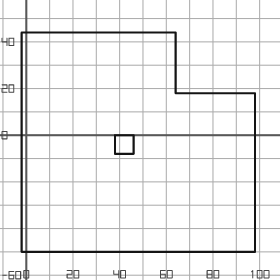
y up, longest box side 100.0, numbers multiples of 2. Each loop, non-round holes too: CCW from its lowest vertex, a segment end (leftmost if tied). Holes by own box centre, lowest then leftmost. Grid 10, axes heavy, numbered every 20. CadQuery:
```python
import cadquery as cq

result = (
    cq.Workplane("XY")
    .moveTo(-2.0, -50.0)
    .lineTo(98.0, -50.0)
    .lineTo(98.0, 18.0)
    .lineTo(64.0, 18.0)
    .lineTo(64.0, 44.0)
    .lineTo(-2.0, 44.0)
    .close()
    .moveTo(38.0, -8.0)
    .lineTo(46.0, -8.0)
    .lineTo(46.0, 0.0)
    .lineTo(38.0, 0.0)
    .close()
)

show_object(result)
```